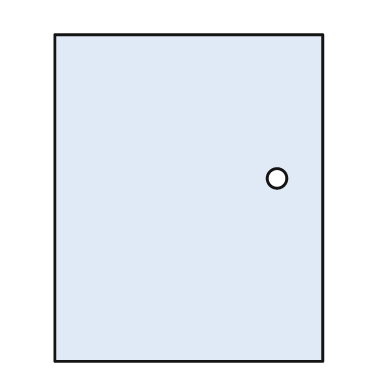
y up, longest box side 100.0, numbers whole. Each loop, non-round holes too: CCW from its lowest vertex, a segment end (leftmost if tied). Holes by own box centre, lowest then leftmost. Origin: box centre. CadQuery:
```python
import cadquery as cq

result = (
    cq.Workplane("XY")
    .moveTo(-41.0, -50.0)
    .lineTo(41.0, -50.0)
    .lineTo(41.0, 50.0)
    .lineTo(-41.0, 50.0)
    .close()
    .moveTo(27.0, 6.0)
    .circle(3.0)
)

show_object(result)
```